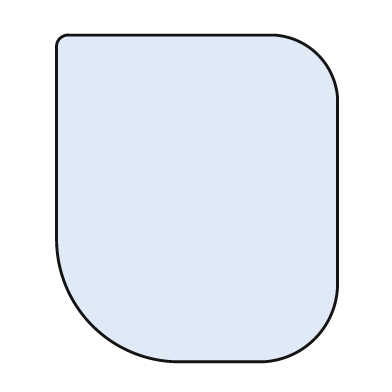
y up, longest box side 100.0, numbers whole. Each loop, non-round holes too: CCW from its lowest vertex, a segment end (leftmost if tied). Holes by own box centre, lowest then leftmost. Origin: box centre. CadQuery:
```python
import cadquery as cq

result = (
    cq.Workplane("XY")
    .moveTo(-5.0, -50.0)
    .lineTo(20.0, -50.0)
    .threePointArc((36.0, -43.0), (43.0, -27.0))
    .lineTo(43.0, 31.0)
    .threePointArc((37.0, 44.0), (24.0, 50.0))
    .lineTo(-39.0, 50.0)
    .threePointArc((-42.0, 49.0), (-43.0, 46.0))
    .lineTo(-43.0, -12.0)
    .threePointArc((-32.0, -39.0), (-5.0, -50.0))
    .close()
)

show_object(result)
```